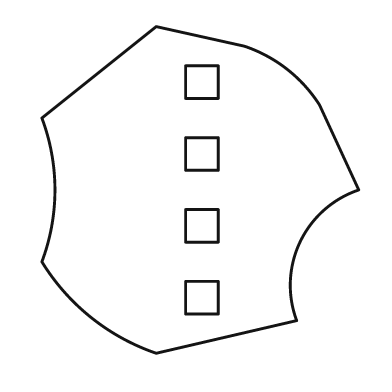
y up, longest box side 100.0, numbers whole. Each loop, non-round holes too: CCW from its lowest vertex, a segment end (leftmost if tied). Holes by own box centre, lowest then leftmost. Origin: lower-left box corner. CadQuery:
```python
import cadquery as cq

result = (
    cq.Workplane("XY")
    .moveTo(35.0, 0.0)
    .lineTo(78.0, 10.0)
    .threePointArc((79.0, 34.0), (97.0, 50.0))
    .lineTo(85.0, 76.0)
    .threePointArc((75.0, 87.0), (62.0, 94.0))
    .lineTo(35.0, 100.0)
    .lineTo(0.0, 72.0)
    .threePointArc((4.0, 50.0), (0.0, 28.0))
    .threePointArc((15.0, 11.0), (35.0, 0.0))
    .close()
    .moveTo(44.0, 12.0)
    .lineTo(54.0, 12.0)
    .lineTo(54.0, 22.0)
    .lineTo(44.0, 22.0)
    .close()
    .moveTo(44.0, 34.0)
    .lineTo(54.0, 34.0)
    .lineTo(54.0, 44.0)
    .lineTo(44.0, 44.0)
    .close()
    .moveTo(44.0, 56.0)
    .lineTo(54.0, 56.0)
    .lineTo(54.0, 66.0)
    .lineTo(44.0, 66.0)
    .close()
    .moveTo(44.0, 78.0)
    .lineTo(54.0, 78.0)
    .lineTo(54.0, 88.0)
    .lineTo(44.0, 88.0)
    .close()
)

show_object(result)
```